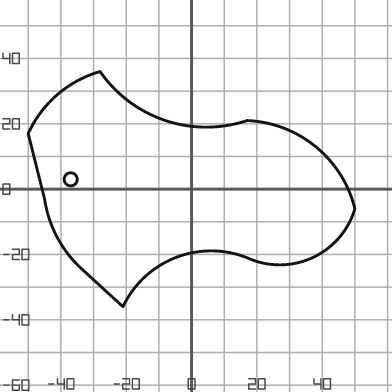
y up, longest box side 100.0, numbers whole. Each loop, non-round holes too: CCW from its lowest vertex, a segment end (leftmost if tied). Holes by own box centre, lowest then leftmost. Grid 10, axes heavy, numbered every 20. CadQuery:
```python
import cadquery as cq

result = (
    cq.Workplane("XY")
    .moveTo(-21.0, -36.0)
    .threePointArc((-5.0, -21.0), (17.0, -21.0))
    .threePointArc((37.0, -21.0), (50.0, -6.0))
    .threePointArc((38.0, 13.0), (17.0, 21.0))
    .threePointArc((-8.0, 21.0), (-28.0, 36.0))
    .threePointArc((-41.0, 29.0), (-50.0, 17.0))
    .lineTo(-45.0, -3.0)
    .threePointArc((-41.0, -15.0), (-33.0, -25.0))
    .close()
    .moveTo(-37.0, 3.0)
    .circle(2.0)
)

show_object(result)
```